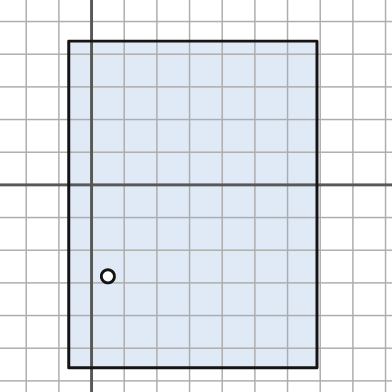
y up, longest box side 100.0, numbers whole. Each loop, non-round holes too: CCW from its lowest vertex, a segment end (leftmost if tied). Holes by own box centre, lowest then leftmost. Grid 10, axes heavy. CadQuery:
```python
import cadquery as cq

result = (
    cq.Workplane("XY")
    .moveTo(-7.0, -56.0)
    .lineTo(69.0, -56.0)
    .lineTo(69.0, 44.0)
    .lineTo(-7.0, 44.0)
    .close()
    .moveTo(5.0, -28.0)
    .circle(2.0)
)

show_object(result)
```